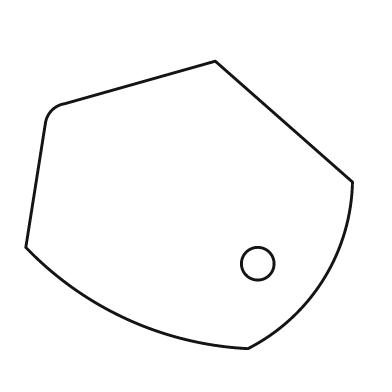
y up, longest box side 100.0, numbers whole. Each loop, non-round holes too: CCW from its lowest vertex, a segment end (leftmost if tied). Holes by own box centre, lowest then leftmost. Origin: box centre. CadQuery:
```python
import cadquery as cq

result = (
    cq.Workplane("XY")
    .moveTo(18.0, -44.0)
    .threePointArc((41.0, -23.0), (50.0, 7.0))
    .lineTo(8.0, 44.0)
    .lineTo(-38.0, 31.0)
    .threePointArc((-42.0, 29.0), (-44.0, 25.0))
    .lineTo(-50.0, -13.0)
    .threePointArc((-19.0, -35.0), (18.0, -44.0))
    .close()
    .moveTo(21.0, -18.0)
    .circle(5.0)
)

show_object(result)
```